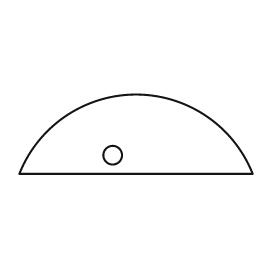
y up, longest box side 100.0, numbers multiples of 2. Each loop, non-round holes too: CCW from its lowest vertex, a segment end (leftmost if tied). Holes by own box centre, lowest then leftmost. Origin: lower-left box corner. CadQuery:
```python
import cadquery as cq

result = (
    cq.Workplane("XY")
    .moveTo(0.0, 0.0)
    .lineTo(100.0, 0.0)
    .threePointArc((50.0, 34.0), (0.0, 0.0))
    .close()
    .moveTo(40.0, 8.0)
    .circle(4.0)
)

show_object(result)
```